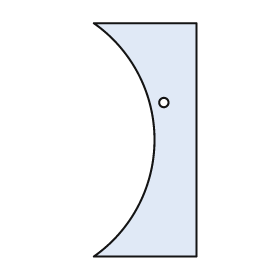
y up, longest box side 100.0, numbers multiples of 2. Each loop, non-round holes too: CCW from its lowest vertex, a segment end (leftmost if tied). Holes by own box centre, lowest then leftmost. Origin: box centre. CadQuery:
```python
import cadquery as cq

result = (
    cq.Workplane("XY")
    .moveTo(-22.0, -50.0)
    .lineTo(22.0, -50.0)
    .lineTo(22.0, 50.0)
    .lineTo(-22.0, 50.0)
    .threePointArc((4.0, 0.0), (-22.0, -50.0))
    .close()
    .moveTo(8.0, 16.0)
    .circle(2.0)
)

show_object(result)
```